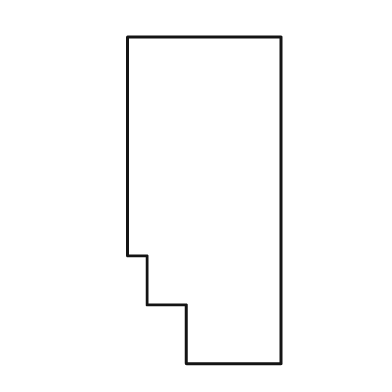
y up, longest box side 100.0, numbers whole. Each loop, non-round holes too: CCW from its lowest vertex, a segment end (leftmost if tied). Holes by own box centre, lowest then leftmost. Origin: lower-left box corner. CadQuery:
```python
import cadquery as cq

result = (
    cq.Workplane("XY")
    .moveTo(18.0, 0.0)
    .lineTo(47.0, 0.0)
    .lineTo(47.0, 100.0)
    .lineTo(0.0, 100.0)
    .lineTo(0.0, 33.0)
    .lineTo(6.0, 33.0)
    .lineTo(6.0, 18.0)
    .lineTo(18.0, 18.0)
    .close()
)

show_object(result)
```